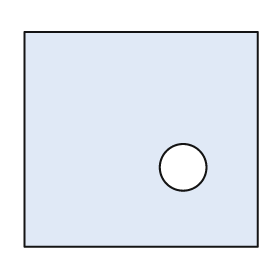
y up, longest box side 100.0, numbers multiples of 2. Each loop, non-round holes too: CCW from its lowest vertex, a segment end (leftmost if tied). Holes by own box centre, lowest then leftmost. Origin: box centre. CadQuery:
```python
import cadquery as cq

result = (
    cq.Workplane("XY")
    .moveTo(-50.0, -46.0)
    .lineTo(50.0, -46.0)
    .lineTo(50.0, 46.0)
    .lineTo(-50.0, 46.0)
    .close()
    .moveTo(18.0, -12.0)
    .circle(10.0)
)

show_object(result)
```